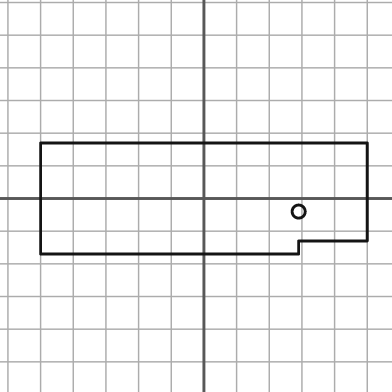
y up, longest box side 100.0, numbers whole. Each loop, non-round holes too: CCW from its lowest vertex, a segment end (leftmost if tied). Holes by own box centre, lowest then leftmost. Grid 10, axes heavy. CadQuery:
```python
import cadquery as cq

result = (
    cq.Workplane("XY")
    .moveTo(-50.0, -17.0)
    .lineTo(29.0, -17.0)
    .lineTo(29.0, -13.0)
    .lineTo(50.0, -13.0)
    .lineTo(50.0, 17.0)
    .lineTo(-50.0, 17.0)
    .close()
    .moveTo(29.0, -4.0)
    .circle(2.0)
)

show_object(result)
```